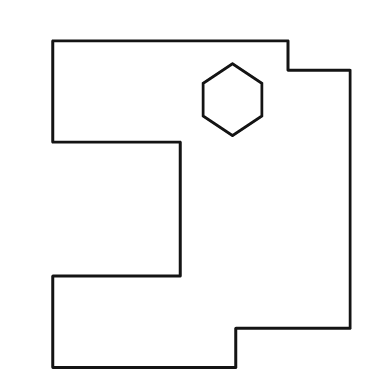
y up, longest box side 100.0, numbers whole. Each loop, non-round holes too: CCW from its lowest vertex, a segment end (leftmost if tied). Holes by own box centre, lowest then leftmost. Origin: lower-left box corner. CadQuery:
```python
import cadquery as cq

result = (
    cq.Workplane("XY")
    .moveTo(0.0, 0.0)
    .lineTo(56.0, 0.0)
    .lineTo(56.0, 12.0)
    .lineTo(91.0, 12.0)
    .lineTo(91.0, 91.0)
    .lineTo(72.0, 91.0)
    .lineTo(72.0, 100.0)
    .lineTo(0.0, 100.0)
    .lineTo(0.0, 69.0)
    .lineTo(39.0, 69.0)
    .lineTo(39.0, 28.0)
    .lineTo(0.0, 28.0)
    .close()
    .moveTo(55.0, 71.0)
    .lineTo(64.0, 77.0)
    .lineTo(64.0, 87.0)
    .lineTo(55.0, 93.0)
    .lineTo(46.0, 87.0)
    .lineTo(46.0, 77.0)
    .close()
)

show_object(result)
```